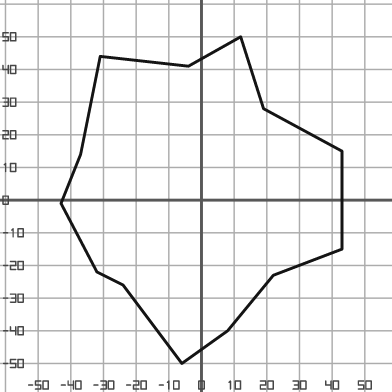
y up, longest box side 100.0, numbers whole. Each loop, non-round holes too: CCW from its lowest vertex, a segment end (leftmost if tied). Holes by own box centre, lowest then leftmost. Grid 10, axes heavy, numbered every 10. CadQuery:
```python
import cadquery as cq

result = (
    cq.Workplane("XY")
    .moveTo(-6.0, -50.0)
    .lineTo(8.0, -40.0)
    .lineTo(22.0, -23.0)
    .lineTo(43.0, -15.0)
    .lineTo(43.0, 15.0)
    .lineTo(19.0, 28.0)
    .lineTo(12.0, 50.0)
    .lineTo(-4.0, 41.0)
    .lineTo(-31.0, 44.0)
    .lineTo(-37.0, 14.0)
    .lineTo(-43.0, -1.0)
    .lineTo(-32.0, -22.0)
    .lineTo(-24.0, -26.0)
    .close()
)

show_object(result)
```